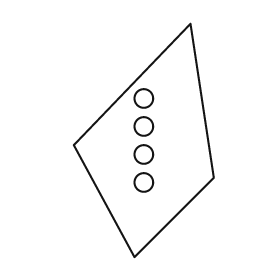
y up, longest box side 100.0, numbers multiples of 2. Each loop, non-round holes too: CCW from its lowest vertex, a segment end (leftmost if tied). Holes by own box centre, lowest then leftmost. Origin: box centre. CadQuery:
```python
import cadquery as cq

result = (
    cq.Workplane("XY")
    .moveTo(-4.0, -50.0)
    .lineTo(30.0, -16.0)
    .lineTo(20.0, 50.0)
    .lineTo(-30.0, -2.0)
    .close()
    .moveTo(0.0, -18.0)
    .circle(4.0)
    .moveTo(0.0, -6.0)
    .circle(4.0)
    .moveTo(0.0, 6.0)
    .circle(4.0)
    .moveTo(0.0, 18.0)
    .circle(4.0)
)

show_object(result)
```